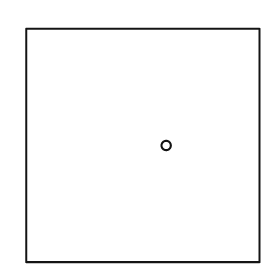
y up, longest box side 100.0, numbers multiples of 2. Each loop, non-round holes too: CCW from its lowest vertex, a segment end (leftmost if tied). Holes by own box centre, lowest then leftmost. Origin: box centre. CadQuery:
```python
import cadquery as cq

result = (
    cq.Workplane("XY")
    .moveTo(-50.0, -50.0)
    .lineTo(50.0, -50.0)
    .lineTo(50.0, 50.0)
    .lineTo(-50.0, 50.0)
    .close()
    .moveTo(10.0, 0.0)
    .circle(2.0)
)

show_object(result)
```